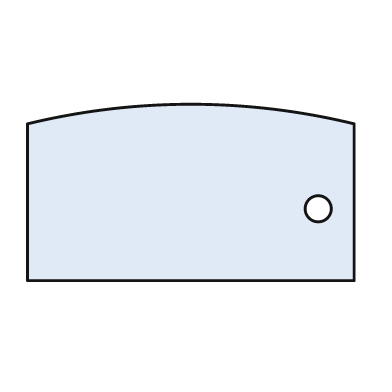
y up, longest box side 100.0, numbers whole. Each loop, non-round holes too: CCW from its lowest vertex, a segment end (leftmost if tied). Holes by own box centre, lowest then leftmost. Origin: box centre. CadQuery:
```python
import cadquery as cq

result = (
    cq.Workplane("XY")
    .moveTo(-50.0, -27.0)
    .lineTo(50.0, -27.0)
    .lineTo(50.0, 21.0)
    .threePointArc((0.0, 27.0), (-50.0, 21.0))
    .close()
    .moveTo(39.0, -5.0)
    .circle(4.0)
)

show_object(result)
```